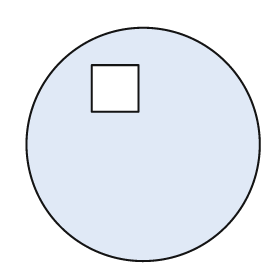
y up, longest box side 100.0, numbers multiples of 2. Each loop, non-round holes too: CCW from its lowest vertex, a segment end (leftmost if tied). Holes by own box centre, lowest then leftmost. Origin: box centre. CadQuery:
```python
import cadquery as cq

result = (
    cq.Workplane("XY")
    .moveTo(0.0, 0.0)
    .circle(50.0)
    .moveTo(-22.0, 14.0)
    .lineTo(-2.0, 14.0)
    .lineTo(-2.0, 34.0)
    .lineTo(-22.0, 34.0)
    .close()
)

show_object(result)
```